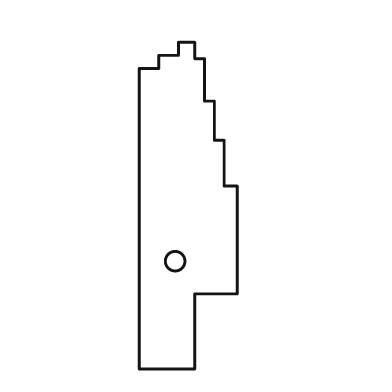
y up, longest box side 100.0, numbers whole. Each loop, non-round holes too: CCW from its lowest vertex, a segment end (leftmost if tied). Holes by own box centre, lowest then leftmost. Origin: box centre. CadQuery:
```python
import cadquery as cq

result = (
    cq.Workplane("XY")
    .moveTo(-15.0, -50.0)
    .lineTo(2.0, -50.0)
    .lineTo(2.0, -27.0)
    .lineTo(15.0, -27.0)
    .lineTo(15.0, 6.0)
    .lineTo(11.0, 6.0)
    .lineTo(11.0, 20.0)
    .lineTo(8.0, 20.0)
    .lineTo(8.0, 32.0)
    .lineTo(5.0, 32.0)
    .lineTo(5.0, 45.0)
    .lineTo(2.0, 45.0)
    .lineTo(2.0, 50.0)
    .lineTo(-3.0, 50.0)
    .lineTo(-3.0, 46.0)
    .lineTo(-9.0, 46.0)
    .lineTo(-9.0, 42.0)
    .lineTo(-15.0, 42.0)
    .close()
    .moveTo(-4.0, -17.0)
    .circle(3.0)
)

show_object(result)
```